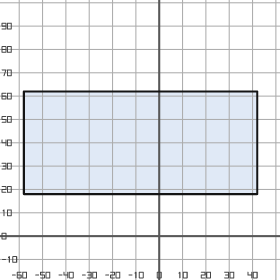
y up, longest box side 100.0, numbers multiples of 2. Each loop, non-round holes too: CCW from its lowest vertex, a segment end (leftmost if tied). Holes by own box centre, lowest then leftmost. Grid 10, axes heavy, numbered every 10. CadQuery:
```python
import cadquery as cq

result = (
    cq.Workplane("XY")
    .moveTo(-58.0, 18.0)
    .lineTo(42.0, 18.0)
    .lineTo(42.0, 62.0)
    .lineTo(-58.0, 62.0)
    .close()
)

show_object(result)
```